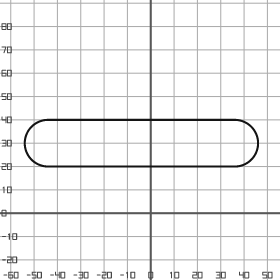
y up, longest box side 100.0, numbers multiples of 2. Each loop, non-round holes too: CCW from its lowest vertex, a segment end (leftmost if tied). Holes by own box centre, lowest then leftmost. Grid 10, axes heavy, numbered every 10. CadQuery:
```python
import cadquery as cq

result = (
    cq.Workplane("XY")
    .moveTo(-44.0, 20.0)
    .lineTo(36.0, 20.0)
    .threePointArc((46.0, 30.0), (36.0, 40.0))
    .lineTo(-44.0, 40.0)
    .threePointArc((-54.0, 30.0), (-44.0, 20.0))
    .close()
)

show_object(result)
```